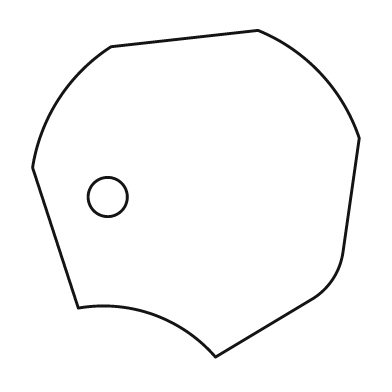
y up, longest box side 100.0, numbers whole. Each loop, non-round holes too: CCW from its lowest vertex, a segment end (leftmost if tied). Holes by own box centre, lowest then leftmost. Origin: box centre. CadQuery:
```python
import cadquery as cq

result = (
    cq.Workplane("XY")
    .moveTo(6.0, -50.0)
    .lineTo(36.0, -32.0)
    .threePointArc((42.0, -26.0), (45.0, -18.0))
    .lineTo(50.0, 17.0)
    .threePointArc((38.0, 37.0), (19.0, 50.0))
    .lineTo(-26.0, 45.0)
    .threePointArc((-42.0, 29.0), (-50.0, 8.0))
    .lineTo(-36.0, -35.0)
    .threePointArc((-13.0, -37.0), (6.0, -50.0))
    .close()
    .moveTo(-27.0, -1.0)
    .circle(6.0)
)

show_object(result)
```